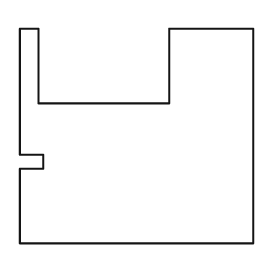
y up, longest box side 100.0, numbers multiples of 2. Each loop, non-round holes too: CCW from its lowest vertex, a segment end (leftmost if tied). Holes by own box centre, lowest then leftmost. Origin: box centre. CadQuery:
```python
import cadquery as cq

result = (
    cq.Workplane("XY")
    .moveTo(-50.0, -46.0)
    .lineTo(50.0, -46.0)
    .lineTo(50.0, 46.0)
    .lineTo(14.0, 46.0)
    .lineTo(14.0, 14.0)
    .lineTo(-42.0, 14.0)
    .lineTo(-42.0, 46.0)
    .lineTo(-50.0, 46.0)
    .lineTo(-50.0, -8.0)
    .lineTo(-40.0, -8.0)
    .lineTo(-40.0, -14.0)
    .lineTo(-50.0, -14.0)
    .close()
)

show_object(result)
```